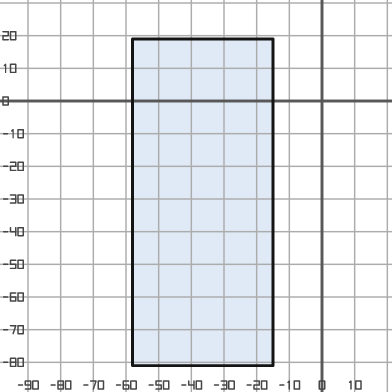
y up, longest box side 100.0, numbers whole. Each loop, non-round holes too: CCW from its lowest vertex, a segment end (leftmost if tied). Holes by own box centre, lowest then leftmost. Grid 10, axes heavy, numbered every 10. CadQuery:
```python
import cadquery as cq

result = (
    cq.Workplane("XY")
    .moveTo(-58.0, -81.0)
    .lineTo(-15.0, -81.0)
    .lineTo(-15.0, 19.0)
    .lineTo(-58.0, 19.0)
    .close()
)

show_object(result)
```